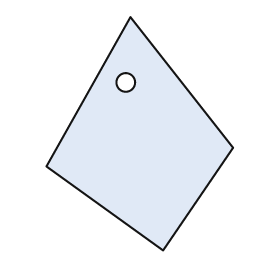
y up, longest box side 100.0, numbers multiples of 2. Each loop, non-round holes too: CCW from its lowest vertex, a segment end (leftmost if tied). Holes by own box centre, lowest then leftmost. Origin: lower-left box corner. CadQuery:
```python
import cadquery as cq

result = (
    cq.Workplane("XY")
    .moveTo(50.0, 0.0)
    .lineTo(80.0, 44.0)
    .lineTo(36.0, 100.0)
    .lineTo(0.0, 36.0)
    .close()
    .moveTo(34.0, 72.0)
    .circle(4.0)
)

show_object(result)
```